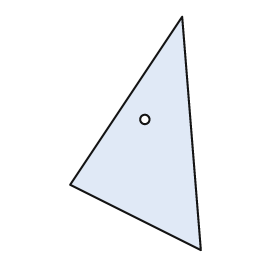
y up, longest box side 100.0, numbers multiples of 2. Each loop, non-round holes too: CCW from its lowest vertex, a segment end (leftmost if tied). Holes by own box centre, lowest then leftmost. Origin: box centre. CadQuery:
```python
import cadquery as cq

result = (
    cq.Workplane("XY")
    .moveTo(28.0, -50.0)
    .lineTo(20.0, 50.0)
    .lineTo(-28.0, -22.0)
    .close()
    .moveTo(4.0, 6.0)
    .circle(2.0)
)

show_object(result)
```